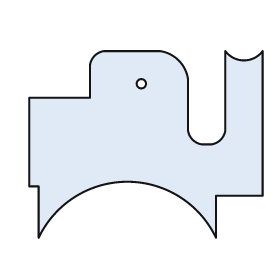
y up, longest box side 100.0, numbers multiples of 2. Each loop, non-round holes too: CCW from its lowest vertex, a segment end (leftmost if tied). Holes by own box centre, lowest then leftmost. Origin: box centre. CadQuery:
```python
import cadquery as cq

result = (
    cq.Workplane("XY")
    .moveTo(-46.0, -40.0)
    .threePointArc((-8.0, -16.0), (30.0, -40.0))
    .lineTo(30.0, -22.0)
    .lineTo(50.0, -22.0)
    .lineTo(50.0, 40.0)
    .threePointArc((42.0, 36.0), (34.0, 40.0))
    .lineTo(34.0, 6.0)
    .threePointArc((32.0, 2.0), (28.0, 0.0))
    .lineTo(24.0, 0.0)
    .threePointArc((20.0, 2.0), (18.0, 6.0))
    .lineTo(18.0, 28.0)
    .threePointArc((14.0, 36.0), (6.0, 40.0))
    .lineTo(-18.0, 40.0)
    .threePointArc((-22.0, 38.0), (-24.0, 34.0))
    .lineTo(-24.0, 20.0)
    .lineTo(-50.0, 20.0)
    .lineTo(-50.0, -18.0)
    .lineTo(-46.0, -18.0)
    .close()
    .moveTo(-2.0, 26.0)
    .circle(2.0)
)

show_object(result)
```